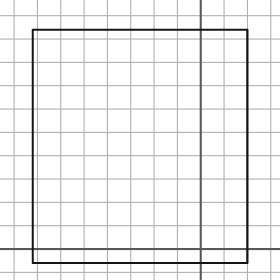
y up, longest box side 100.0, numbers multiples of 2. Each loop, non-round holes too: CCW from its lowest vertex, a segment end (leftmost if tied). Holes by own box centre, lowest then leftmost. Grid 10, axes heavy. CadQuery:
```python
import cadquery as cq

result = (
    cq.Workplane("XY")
    .moveTo(-72.0, -6.0)
    .lineTo(20.0, -6.0)
    .lineTo(20.0, 94.0)
    .lineTo(-72.0, 94.0)
    .close()
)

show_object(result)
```